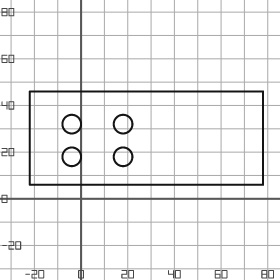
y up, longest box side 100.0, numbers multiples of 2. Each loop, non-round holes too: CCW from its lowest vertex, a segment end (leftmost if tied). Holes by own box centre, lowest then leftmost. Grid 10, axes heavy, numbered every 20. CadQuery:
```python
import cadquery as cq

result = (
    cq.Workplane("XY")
    .moveTo(-22.0, 6.0)
    .lineTo(78.0, 6.0)
    .lineTo(78.0, 46.0)
    .lineTo(-22.0, 46.0)
    .close()
    .moveTo(-4.0, 18.0)
    .circle(4.0)
    .moveTo(18.0, 18.0)
    .circle(4.0)
    .moveTo(-4.0, 32.0)
    .circle(4.0)
    .moveTo(18.0, 32.0)
    .circle(4.0)
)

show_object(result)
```